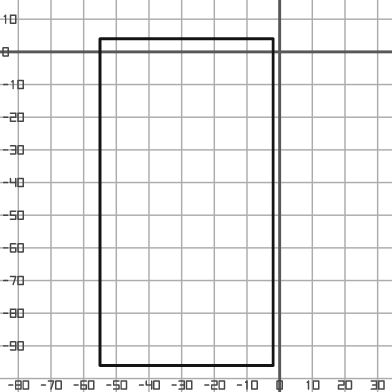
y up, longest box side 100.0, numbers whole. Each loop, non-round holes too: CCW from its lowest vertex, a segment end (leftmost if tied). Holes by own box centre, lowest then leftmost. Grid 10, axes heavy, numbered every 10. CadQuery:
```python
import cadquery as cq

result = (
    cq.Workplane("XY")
    .moveTo(-55.0, -96.0)
    .lineTo(-2.0, -96.0)
    .lineTo(-2.0, 4.0)
    .lineTo(-55.0, 4.0)
    .close()
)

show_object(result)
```